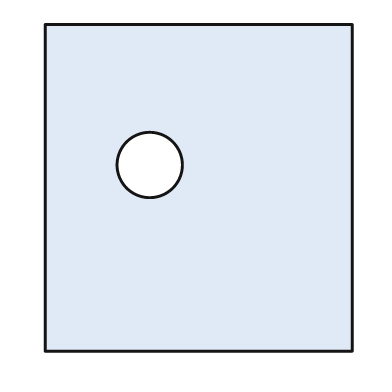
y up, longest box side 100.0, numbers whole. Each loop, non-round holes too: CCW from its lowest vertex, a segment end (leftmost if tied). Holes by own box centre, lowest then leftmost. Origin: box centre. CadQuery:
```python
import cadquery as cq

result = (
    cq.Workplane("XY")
    .moveTo(-47.0, -50.0)
    .lineTo(47.0, -50.0)
    .lineTo(47.0, 50.0)
    .lineTo(-47.0, 50.0)
    .close()
    .moveTo(-15.0, 7.0)
    .circle(10.0)
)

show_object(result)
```